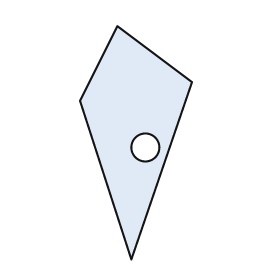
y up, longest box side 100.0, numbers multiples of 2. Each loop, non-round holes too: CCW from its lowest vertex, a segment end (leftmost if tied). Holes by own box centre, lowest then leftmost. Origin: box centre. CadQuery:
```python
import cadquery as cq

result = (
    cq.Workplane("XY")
    .moveTo(-2.0, -50.0)
    .lineTo(24.0, 26.0)
    .lineTo(-8.0, 50.0)
    .lineTo(-24.0, 18.0)
    .close()
    .moveTo(4.0, -2.0)
    .circle(6.0)
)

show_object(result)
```